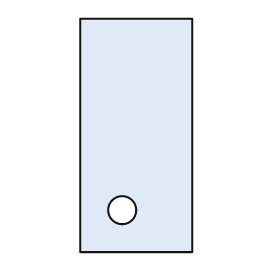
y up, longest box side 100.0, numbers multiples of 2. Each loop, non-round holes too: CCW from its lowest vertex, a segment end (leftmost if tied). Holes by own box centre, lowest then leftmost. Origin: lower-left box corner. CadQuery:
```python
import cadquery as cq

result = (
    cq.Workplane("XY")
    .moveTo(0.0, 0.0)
    .lineTo(48.0, 0.0)
    .lineTo(48.0, 100.0)
    .lineTo(0.0, 100.0)
    .close()
    .moveTo(18.0, 18.0)
    .circle(6.0)
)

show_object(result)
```